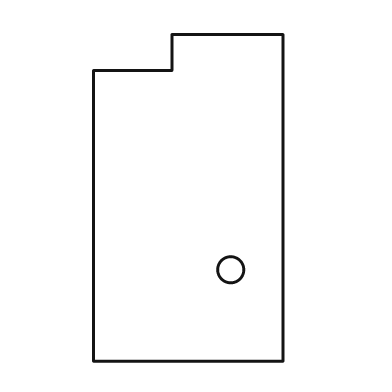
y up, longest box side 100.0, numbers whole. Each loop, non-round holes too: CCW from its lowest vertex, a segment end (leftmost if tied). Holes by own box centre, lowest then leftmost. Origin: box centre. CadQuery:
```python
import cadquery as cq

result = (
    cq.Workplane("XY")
    .moveTo(-29.0, -50.0)
    .lineTo(29.0, -50.0)
    .lineTo(29.0, 50.0)
    .lineTo(-5.0, 50.0)
    .lineTo(-5.0, 39.0)
    .lineTo(-29.0, 39.0)
    .close()
    .moveTo(13.0, -22.0)
    .circle(4.0)
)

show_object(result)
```